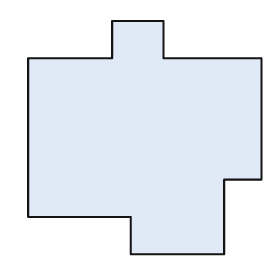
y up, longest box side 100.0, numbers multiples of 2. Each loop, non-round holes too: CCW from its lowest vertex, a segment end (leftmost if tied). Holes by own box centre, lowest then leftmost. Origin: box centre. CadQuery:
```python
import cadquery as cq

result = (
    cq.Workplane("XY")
    .moveTo(-6.0, -50.0)
    .lineTo(34.0, -50.0)
    .lineTo(34.0, -18.0)
    .lineTo(50.0, -18.0)
    .lineTo(50.0, 34.0)
    .lineTo(8.0, 34.0)
    .lineTo(8.0, 50.0)
    .lineTo(-14.0, 50.0)
    .lineTo(-14.0, 34.0)
    .lineTo(-50.0, 34.0)
    .lineTo(-50.0, -34.0)
    .lineTo(-6.0, -34.0)
    .close()
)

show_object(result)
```